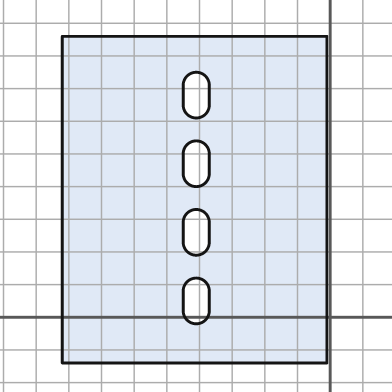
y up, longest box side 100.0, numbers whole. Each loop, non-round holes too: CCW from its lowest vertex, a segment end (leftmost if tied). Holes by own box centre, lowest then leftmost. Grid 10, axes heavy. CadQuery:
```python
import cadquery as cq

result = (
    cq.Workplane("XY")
    .moveTo(-82.0, -14.0)
    .lineTo(-1.0, -14.0)
    .lineTo(-1.0, 86.0)
    .lineTo(-82.0, 86.0)
    .close()
    .moveTo(-45.0, 2.0)
    .threePointArc((-41.0, -2.0), (-37.0, 2.0))
    .lineTo(-37.0, 8.0)
    .threePointArc((-41.0, 12.0), (-45.0, 8.0))
    .close()
    .moveTo(-45.0, 23.0)
    .threePointArc((-41.0, 19.0), (-37.0, 23.0))
    .lineTo(-37.0, 29.0)
    .threePointArc((-41.0, 33.0), (-45.0, 29.0))
    .close()
    .moveTo(-45.0, 44.0)
    .threePointArc((-41.0, 40.0), (-37.0, 44.0))
    .lineTo(-37.0, 50.0)
    .threePointArc((-41.0, 54.0), (-45.0, 50.0))
    .close()
    .moveTo(-45.0, 65.0)
    .threePointArc((-41.0, 61.0), (-37.0, 65.0))
    .lineTo(-37.0, 71.0)
    .threePointArc((-41.0, 75.0), (-45.0, 71.0))
    .close()
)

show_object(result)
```